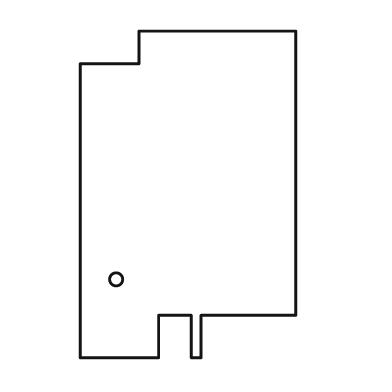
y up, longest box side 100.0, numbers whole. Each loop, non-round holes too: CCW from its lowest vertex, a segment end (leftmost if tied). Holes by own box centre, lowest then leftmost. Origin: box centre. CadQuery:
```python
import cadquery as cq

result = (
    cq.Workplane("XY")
    .moveTo(-33.0, -50.0)
    .lineTo(-9.0, -50.0)
    .lineTo(-9.0, -37.0)
    .lineTo(1.0, -37.0)
    .lineTo(1.0, -50.0)
    .lineTo(4.0, -50.0)
    .lineTo(4.0, -37.0)
    .lineTo(33.0, -37.0)
    .lineTo(33.0, 50.0)
    .lineTo(-15.0, 50.0)
    .lineTo(-15.0, 40.0)
    .lineTo(-33.0, 40.0)
    .close()
    .moveTo(-22.0, -26.0)
    .circle(2.0)
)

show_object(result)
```